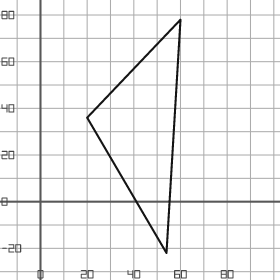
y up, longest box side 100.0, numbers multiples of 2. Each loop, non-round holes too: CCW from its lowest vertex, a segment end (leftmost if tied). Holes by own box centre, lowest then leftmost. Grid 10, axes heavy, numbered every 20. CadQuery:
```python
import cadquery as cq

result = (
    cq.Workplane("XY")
    .moveTo(54.0, -22.0)
    .lineTo(60.0, 78.0)
    .lineTo(20.0, 36.0)
    .close()
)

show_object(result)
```